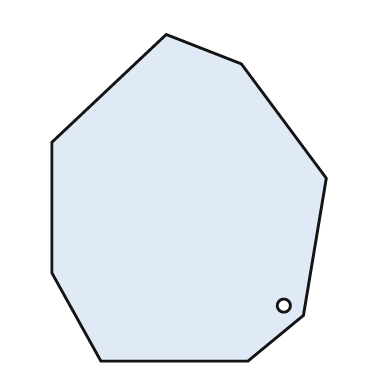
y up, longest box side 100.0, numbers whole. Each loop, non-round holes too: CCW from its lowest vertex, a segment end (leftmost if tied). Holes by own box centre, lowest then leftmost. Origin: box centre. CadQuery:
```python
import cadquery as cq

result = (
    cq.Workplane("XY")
    .moveTo(-27.0, -50.0)
    .lineTo(18.0, -50.0)
    .lineTo(35.0, -36.0)
    .lineTo(42.0, 6.0)
    .lineTo(16.0, 41.0)
    .lineTo(-7.0, 50.0)
    .lineTo(-42.0, 17.0)
    .lineTo(-42.0, -23.0)
    .close()
    .moveTo(29.0, -33.0)
    .circle(2.0)
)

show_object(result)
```